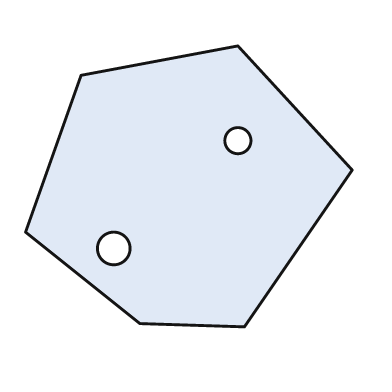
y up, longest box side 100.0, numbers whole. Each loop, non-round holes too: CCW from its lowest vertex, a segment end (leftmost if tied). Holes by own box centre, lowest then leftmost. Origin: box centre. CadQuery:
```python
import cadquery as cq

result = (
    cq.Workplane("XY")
    .moveTo(17.0, -43.0)
    .lineTo(50.0, 5.0)
    .lineTo(15.0, 43.0)
    .lineTo(-33.0, 34.0)
    .lineTo(-50.0, -14.0)
    .lineTo(-15.0, -42.0)
    .close()
    .moveTo(-23.0, -19.0)
    .circle(5.0)
    .moveTo(15.0, 14.0)
    .circle(4.0)
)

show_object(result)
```